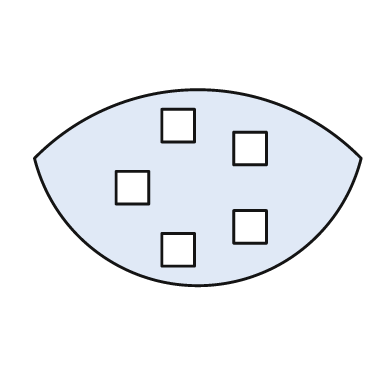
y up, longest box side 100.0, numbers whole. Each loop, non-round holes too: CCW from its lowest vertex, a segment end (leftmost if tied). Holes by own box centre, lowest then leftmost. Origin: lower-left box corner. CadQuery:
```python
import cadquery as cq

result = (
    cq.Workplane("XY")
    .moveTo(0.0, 39.0)
    .threePointArc((50.0, 0.0), (100.0, 39.0))
    .threePointArc((50.0, 60.0), (0.0, 39.0))
    .close()
    .moveTo(39.0, 6.0)
    .lineTo(49.0, 6.0)
    .lineTo(49.0, 16.0)
    .lineTo(39.0, 16.0)
    .close()
    .moveTo(61.0, 13.0)
    .lineTo(71.0, 13.0)
    .lineTo(71.0, 23.0)
    .lineTo(61.0, 23.0)
    .close()
    .moveTo(25.0, 25.0)
    .lineTo(35.0, 25.0)
    .lineTo(35.0, 35.0)
    .lineTo(25.0, 35.0)
    .close()
    .moveTo(61.0, 37.0)
    .lineTo(71.0, 37.0)
    .lineTo(71.0, 47.0)
    .lineTo(61.0, 47.0)
    .close()
    .moveTo(39.0, 44.0)
    .lineTo(49.0, 44.0)
    .lineTo(49.0, 54.0)
    .lineTo(39.0, 54.0)
    .close()
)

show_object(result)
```